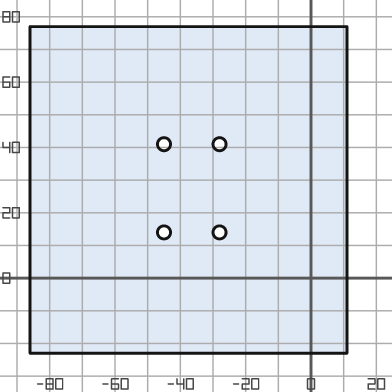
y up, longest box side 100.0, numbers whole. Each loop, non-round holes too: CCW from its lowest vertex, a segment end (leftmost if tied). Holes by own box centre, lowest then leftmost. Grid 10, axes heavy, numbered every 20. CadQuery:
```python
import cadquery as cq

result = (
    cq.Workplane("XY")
    .moveTo(-86.0, -23.0)
    .lineTo(11.0, -23.0)
    .lineTo(11.0, 77.0)
    .lineTo(-86.0, 77.0)
    .close()
    .moveTo(-45.0, 14.0)
    .circle(2.0)
    .moveTo(-28.0, 14.0)
    .circle(2.0)
    .moveTo(-45.0, 41.0)
    .circle(2.0)
    .moveTo(-28.0, 41.0)
    .circle(2.0)
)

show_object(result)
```